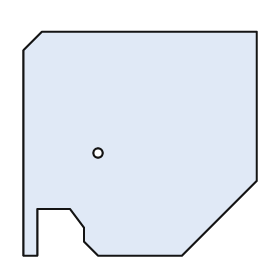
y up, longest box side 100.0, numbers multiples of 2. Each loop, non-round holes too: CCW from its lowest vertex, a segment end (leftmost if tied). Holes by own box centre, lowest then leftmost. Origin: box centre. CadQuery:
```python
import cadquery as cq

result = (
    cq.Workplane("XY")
    .moveTo(-50.0, -48.0)
    .lineTo(-44.0, -48.0)
    .lineTo(-44.0, -28.0)
    .lineTo(-30.0, -28.0)
    .lineTo(-24.0, -36.0)
    .lineTo(-24.0, -42.0)
    .lineTo(-18.0, -48.0)
    .lineTo(18.0, -48.0)
    .lineTo(50.0, -16.0)
    .lineTo(50.0, 48.0)
    .lineTo(-42.0, 48.0)
    .lineTo(-50.0, 40.0)
    .close()
    .moveTo(-18.0, -4.0)
    .circle(2.0)
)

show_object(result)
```